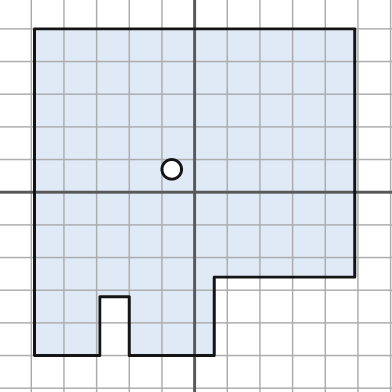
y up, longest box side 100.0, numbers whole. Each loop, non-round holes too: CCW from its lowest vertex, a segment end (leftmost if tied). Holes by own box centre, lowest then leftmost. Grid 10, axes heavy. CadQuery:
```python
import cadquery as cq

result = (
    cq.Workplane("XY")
    .moveTo(-49.0, -50.0)
    .lineTo(-29.0, -50.0)
    .lineTo(-29.0, -32.0)
    .lineTo(-20.0, -32.0)
    .lineTo(-20.0, -50.0)
    .lineTo(6.0, -50.0)
    .lineTo(6.0, -26.0)
    .lineTo(49.0, -26.0)
    .lineTo(49.0, 50.0)
    .lineTo(-49.0, 50.0)
    .close()
    .moveTo(-7.0, 7.0)
    .circle(3.0)
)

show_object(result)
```